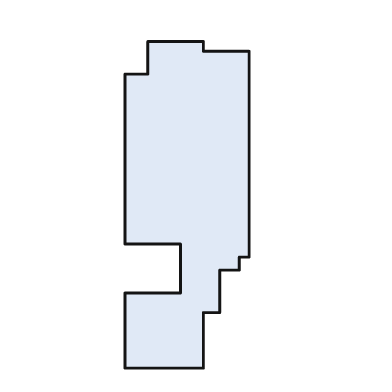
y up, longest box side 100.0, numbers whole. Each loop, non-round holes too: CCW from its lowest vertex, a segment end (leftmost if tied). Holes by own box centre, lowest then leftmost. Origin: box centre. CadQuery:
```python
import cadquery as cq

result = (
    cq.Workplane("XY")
    .moveTo(-19.0, -50.0)
    .lineTo(5.0, -50.0)
    .lineTo(5.0, -33.0)
    .lineTo(10.0, -33.0)
    .lineTo(10.0, -20.0)
    .lineTo(16.0, -20.0)
    .lineTo(16.0, -16.0)
    .lineTo(19.0, -16.0)
    .lineTo(19.0, 47.0)
    .lineTo(5.0, 47.0)
    .lineTo(5.0, 50.0)
    .lineTo(-12.0, 50.0)
    .lineTo(-12.0, 40.0)
    .lineTo(-19.0, 40.0)
    .lineTo(-19.0, -12.0)
    .lineTo(-2.0, -12.0)
    .lineTo(-2.0, -27.0)
    .lineTo(-19.0, -27.0)
    .close()
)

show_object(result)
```